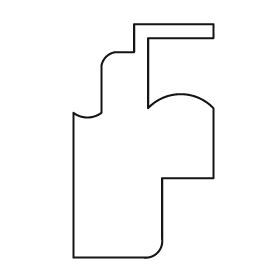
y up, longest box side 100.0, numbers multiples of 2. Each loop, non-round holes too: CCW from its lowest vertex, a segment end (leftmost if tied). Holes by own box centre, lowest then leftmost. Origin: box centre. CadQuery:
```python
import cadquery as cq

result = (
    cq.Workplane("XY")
    .moveTo(-30.0, -50.0)
    .lineTo(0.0, -50.0)
    .threePointArc((6.0, -48.0), (8.0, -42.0))
    .lineTo(8.0, -16.0)
    .lineTo(30.0, -16.0)
    .lineTo(30.0, 14.0)
    .threePointArc((16.0, 20.0), (2.0, 14.0))
    .lineTo(2.0, 44.0)
    .lineTo(30.0, 44.0)
    .lineTo(30.0, 50.0)
    .lineTo(-4.0, 50.0)
    .lineTo(-4.0, 38.0)
    .lineTo(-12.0, 38.0)
    .threePointArc((-16.0, 36.0), (-18.0, 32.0))
    .lineTo(-18.0, 12.0)
    .threePointArc((-24.0, 10.0), (-30.0, 12.0))
    .close()
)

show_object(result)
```